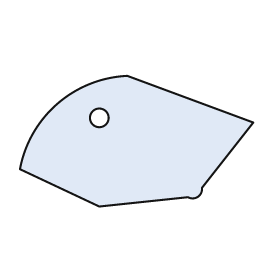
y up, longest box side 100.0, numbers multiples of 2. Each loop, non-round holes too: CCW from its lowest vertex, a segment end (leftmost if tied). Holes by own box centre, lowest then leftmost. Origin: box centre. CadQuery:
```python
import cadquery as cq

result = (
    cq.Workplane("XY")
    .moveTo(-16.0, -28.0)
    .lineTo(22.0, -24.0)
    .threePointArc((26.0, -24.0), (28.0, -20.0))
    .lineTo(50.0, 8.0)
    .lineTo(-4.0, 28.0)
    .threePointArc((-34.0, 16.0), (-50.0, -12.0))
    .close()
    .moveTo(-16.0, 10.0)
    .circle(4.0)
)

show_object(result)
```